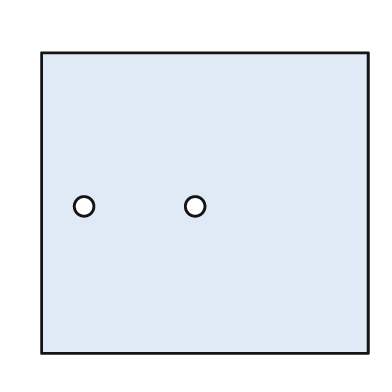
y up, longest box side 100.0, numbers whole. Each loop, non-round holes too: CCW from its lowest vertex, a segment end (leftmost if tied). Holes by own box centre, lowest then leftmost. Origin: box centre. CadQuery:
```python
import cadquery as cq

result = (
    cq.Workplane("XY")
    .moveTo(-50.0, -46.0)
    .lineTo(50.0, -46.0)
    .lineTo(50.0, 46.0)
    .lineTo(-50.0, 46.0)
    .close()
    .moveTo(-37.0, -1.0)
    .circle(3.0)
    .moveTo(-3.0, -1.0)
    .circle(3.0)
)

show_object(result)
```